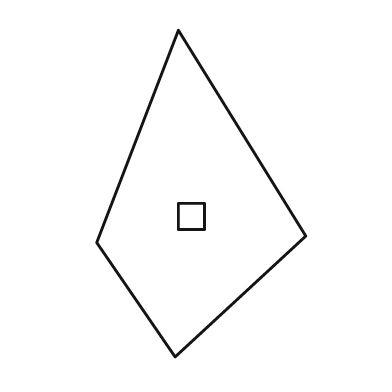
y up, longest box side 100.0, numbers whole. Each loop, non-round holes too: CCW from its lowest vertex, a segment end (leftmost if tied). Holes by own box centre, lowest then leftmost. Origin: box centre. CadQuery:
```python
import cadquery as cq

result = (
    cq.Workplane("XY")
    .moveTo(-8.0, -50.0)
    .lineTo(32.0, -13.0)
    .lineTo(-7.0, 50.0)
    .lineTo(-32.0, -15.0)
    .close()
    .moveTo(-7.0, -11.0)
    .lineTo(1.0, -11.0)
    .lineTo(1.0, -3.0)
    .lineTo(-7.0, -3.0)
    .close()
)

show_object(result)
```